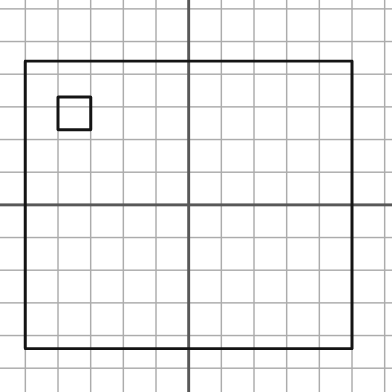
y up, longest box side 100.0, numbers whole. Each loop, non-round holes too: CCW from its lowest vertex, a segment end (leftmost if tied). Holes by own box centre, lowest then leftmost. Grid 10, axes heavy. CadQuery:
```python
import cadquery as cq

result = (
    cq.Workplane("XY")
    .moveTo(-50.0, -44.0)
    .lineTo(50.0, -44.0)
    .lineTo(50.0, 44.0)
    .lineTo(-50.0, 44.0)
    .close()
    .moveTo(-40.0, 23.0)
    .lineTo(-30.0, 23.0)
    .lineTo(-30.0, 33.0)
    .lineTo(-40.0, 33.0)
    .close()
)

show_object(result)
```